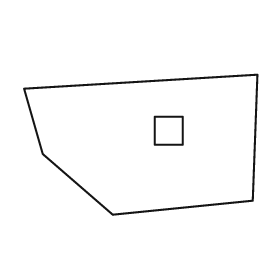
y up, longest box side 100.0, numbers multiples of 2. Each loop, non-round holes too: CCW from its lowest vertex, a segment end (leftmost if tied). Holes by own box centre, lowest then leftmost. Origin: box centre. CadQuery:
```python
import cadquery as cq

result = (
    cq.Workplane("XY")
    .moveTo(-12.0, -30.0)
    .lineTo(48.0, -24.0)
    .lineTo(50.0, 30.0)
    .lineTo(-50.0, 24.0)
    .lineTo(-42.0, -4.0)
    .close()
    .moveTo(6.0, 0.0)
    .lineTo(18.0, 0.0)
    .lineTo(18.0, 12.0)
    .lineTo(6.0, 12.0)
    .close()
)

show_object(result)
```